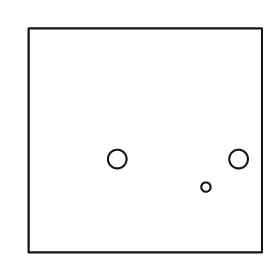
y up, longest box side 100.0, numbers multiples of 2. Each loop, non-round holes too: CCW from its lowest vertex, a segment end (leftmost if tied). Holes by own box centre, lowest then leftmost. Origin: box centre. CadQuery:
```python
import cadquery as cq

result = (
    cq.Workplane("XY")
    .moveTo(-50.0, -48.0)
    .lineTo(50.0, -48.0)
    .lineTo(50.0, 48.0)
    .lineTo(-50.0, 48.0)
    .close()
    .moveTo(26.0, -20.0)
    .circle(2.0)
    .moveTo(-12.0, -8.0)
    .circle(4.0)
    .moveTo(40.0, -8.0)
    .circle(4.0)
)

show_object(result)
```